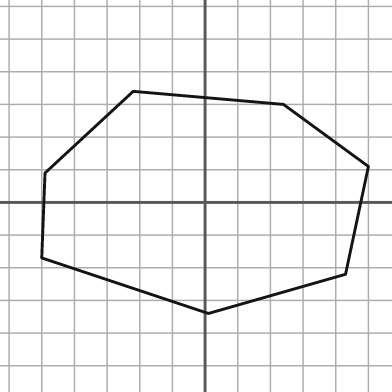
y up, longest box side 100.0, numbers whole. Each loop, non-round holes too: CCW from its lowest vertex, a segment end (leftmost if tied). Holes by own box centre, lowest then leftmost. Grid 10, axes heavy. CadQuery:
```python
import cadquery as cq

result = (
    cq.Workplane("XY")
    .moveTo(1.0, -34.0)
    .lineTo(43.0, -22.0)
    .lineTo(50.0, 11.0)
    .lineTo(24.0, 30.0)
    .lineTo(-22.0, 34.0)
    .lineTo(-49.0, 9.0)
    .lineTo(-50.0, -17.0)
    .close()
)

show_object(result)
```